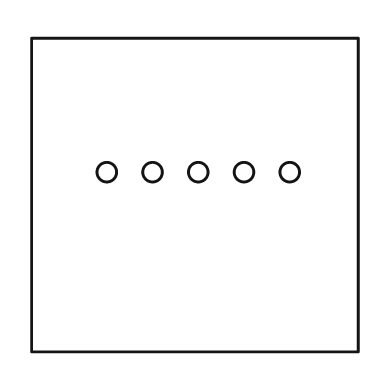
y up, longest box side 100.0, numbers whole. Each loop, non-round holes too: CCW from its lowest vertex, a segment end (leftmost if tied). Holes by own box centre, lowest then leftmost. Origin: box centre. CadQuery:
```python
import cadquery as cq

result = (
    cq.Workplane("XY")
    .moveTo(-50.0, -48.0)
    .lineTo(50.0, -48.0)
    .lineTo(50.0, 48.0)
    .lineTo(-50.0, 48.0)
    .close()
    .moveTo(-27.0, 7.0)
    .circle(3.0)
    .moveTo(-13.0, 7.0)
    .circle(3.0)
    .moveTo(1.0, 7.0)
    .circle(3.0)
    .moveTo(15.0, 7.0)
    .circle(3.0)
    .moveTo(29.0, 7.0)
    .circle(3.0)
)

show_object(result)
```